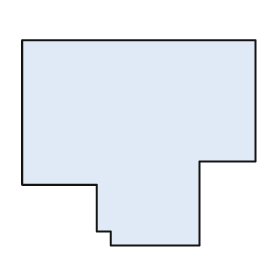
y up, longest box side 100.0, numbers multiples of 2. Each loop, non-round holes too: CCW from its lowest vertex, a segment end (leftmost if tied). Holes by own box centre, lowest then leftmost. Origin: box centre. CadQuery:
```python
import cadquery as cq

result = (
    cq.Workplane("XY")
    .moveTo(-12.0, -44.0)
    .lineTo(26.0, -44.0)
    .lineTo(26.0, -8.0)
    .lineTo(50.0, -8.0)
    .lineTo(50.0, 44.0)
    .lineTo(-50.0, 44.0)
    .lineTo(-50.0, -18.0)
    .lineTo(-18.0, -18.0)
    .lineTo(-18.0, -38.0)
    .lineTo(-12.0, -38.0)
    .close()
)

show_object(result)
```